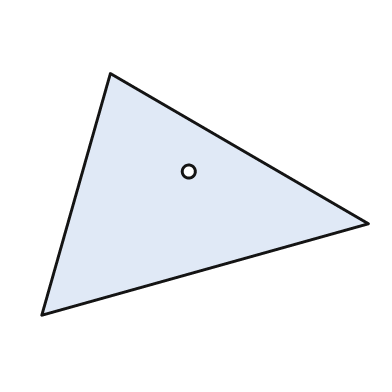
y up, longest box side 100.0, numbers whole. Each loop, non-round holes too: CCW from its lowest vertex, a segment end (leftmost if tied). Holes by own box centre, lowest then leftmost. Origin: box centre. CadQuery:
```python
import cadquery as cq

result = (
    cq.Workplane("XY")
    .moveTo(-50.0, -37.0)
    .lineTo(50.0, -9.0)
    .lineTo(-29.0, 37.0)
    .close()
    .moveTo(-5.0, 7.0)
    .circle(2.0)
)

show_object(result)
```